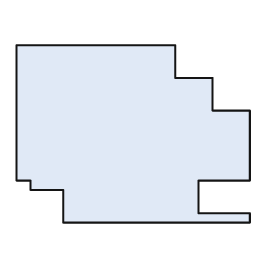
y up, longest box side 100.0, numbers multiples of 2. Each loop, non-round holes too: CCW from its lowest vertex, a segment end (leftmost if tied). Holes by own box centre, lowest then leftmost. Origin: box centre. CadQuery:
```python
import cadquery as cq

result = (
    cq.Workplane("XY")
    .moveTo(-30.0, -38.0)
    .lineTo(50.0, -38.0)
    .lineTo(50.0, -34.0)
    .lineTo(28.0, -34.0)
    .lineTo(28.0, -20.0)
    .lineTo(50.0, -20.0)
    .lineTo(50.0, 10.0)
    .lineTo(34.0, 10.0)
    .lineTo(34.0, 24.0)
    .lineTo(18.0, 24.0)
    .lineTo(18.0, 38.0)
    .lineTo(-50.0, 38.0)
    .lineTo(-50.0, -20.0)
    .lineTo(-44.0, -20.0)
    .lineTo(-44.0, -24.0)
    .lineTo(-30.0, -24.0)
    .close()
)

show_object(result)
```